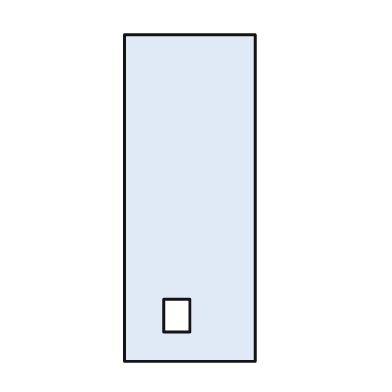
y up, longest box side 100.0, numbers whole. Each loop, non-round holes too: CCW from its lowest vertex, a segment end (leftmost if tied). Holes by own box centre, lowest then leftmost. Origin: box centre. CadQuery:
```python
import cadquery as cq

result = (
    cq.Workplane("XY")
    .moveTo(-20.0, -50.0)
    .lineTo(20.0, -50.0)
    .lineTo(20.0, 50.0)
    .lineTo(-20.0, 50.0)
    .close()
    .moveTo(-8.0, -41.0)
    .lineTo(0.0, -41.0)
    .lineTo(0.0, -31.0)
    .lineTo(-8.0, -31.0)
    .close()
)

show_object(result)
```